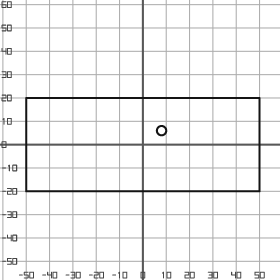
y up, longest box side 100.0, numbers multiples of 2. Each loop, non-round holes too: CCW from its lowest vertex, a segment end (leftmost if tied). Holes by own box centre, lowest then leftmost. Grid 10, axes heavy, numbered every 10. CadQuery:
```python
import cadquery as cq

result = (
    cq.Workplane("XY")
    .moveTo(-50.0, -20.0)
    .lineTo(50.0, -20.0)
    .lineTo(50.0, 20.0)
    .lineTo(-50.0, 20.0)
    .close()
    .moveTo(8.0, 6.0)
    .circle(2.0)
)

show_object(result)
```